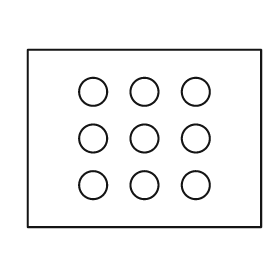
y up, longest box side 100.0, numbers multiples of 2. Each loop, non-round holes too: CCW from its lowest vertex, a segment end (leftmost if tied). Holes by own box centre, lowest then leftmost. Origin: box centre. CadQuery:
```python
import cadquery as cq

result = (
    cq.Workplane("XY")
    .moveTo(-50.0, -38.0)
    .lineTo(50.0, -38.0)
    .lineTo(50.0, 38.0)
    .lineTo(-50.0, 38.0)
    .close()
    .moveTo(-22.0, -20.0)
    .circle(6.0)
    .moveTo(0.0, -20.0)
    .circle(6.0)
    .moveTo(22.0, -20.0)
    .circle(6.0)
    .moveTo(-22.0, 0.0)
    .circle(6.0)
    .moveTo(0.0, 0.0)
    .circle(6.0)
    .moveTo(22.0, 0.0)
    .circle(6.0)
    .moveTo(-22.0, 20.0)
    .circle(6.0)
    .moveTo(0.0, 20.0)
    .circle(6.0)
    .moveTo(22.0, 20.0)
    .circle(6.0)
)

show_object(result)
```